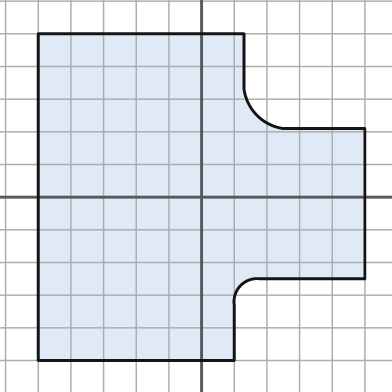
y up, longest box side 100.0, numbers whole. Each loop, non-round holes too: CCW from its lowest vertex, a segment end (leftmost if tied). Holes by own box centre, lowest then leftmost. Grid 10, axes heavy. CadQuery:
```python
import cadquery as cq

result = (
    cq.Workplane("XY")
    .moveTo(-50.0, -50.0)
    .lineTo(10.0, -50.0)
    .lineTo(10.0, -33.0)
    .threePointArc((12.0, -27.0), (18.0, -25.0))
    .lineTo(50.0, -25.0)
    .lineTo(50.0, 21.0)
    .lineTo(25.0, 21.0)
    .threePointArc((17.0, 25.0), (13.0, 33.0))
    .lineTo(13.0, 50.0)
    .lineTo(-50.0, 50.0)
    .close()
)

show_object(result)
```